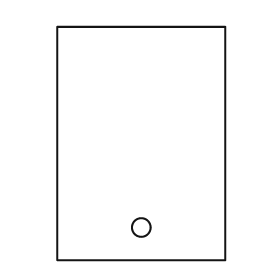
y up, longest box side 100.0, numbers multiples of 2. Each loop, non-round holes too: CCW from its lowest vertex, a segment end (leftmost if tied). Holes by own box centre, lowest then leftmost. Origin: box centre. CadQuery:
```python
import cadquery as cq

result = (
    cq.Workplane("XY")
    .moveTo(-36.0, -50.0)
    .lineTo(36.0, -50.0)
    .lineTo(36.0, 50.0)
    .lineTo(-36.0, 50.0)
    .close()
    .moveTo(0.0, -36.0)
    .circle(4.0)
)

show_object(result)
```